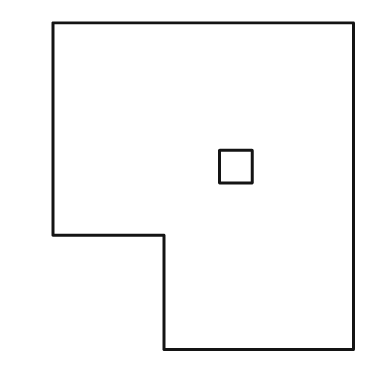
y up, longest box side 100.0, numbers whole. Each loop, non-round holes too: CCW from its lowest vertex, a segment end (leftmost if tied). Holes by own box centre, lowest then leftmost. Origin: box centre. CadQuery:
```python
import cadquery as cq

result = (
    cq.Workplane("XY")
    .moveTo(-12.0, -50.0)
    .lineTo(46.0, -50.0)
    .lineTo(46.0, 50.0)
    .lineTo(-46.0, 50.0)
    .lineTo(-46.0, -15.0)
    .lineTo(-12.0, -15.0)
    .close()
    .moveTo(5.0, 1.0)
    .lineTo(15.0, 1.0)
    .lineTo(15.0, 11.0)
    .lineTo(5.0, 11.0)
    .close()
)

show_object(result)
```